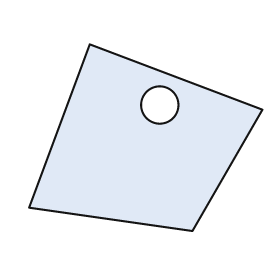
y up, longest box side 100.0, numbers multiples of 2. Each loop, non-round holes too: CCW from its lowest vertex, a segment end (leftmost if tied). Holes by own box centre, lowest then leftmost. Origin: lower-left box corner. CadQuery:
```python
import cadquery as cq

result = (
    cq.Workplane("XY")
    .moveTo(70.0, 0.0)
    .lineTo(100.0, 52.0)
    .lineTo(26.0, 80.0)
    .lineTo(0.0, 10.0)
    .close()
    .moveTo(56.0, 54.0)
    .circle(8.0)
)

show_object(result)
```